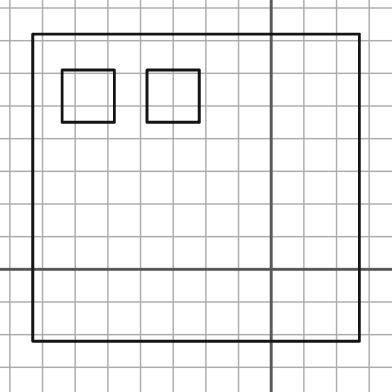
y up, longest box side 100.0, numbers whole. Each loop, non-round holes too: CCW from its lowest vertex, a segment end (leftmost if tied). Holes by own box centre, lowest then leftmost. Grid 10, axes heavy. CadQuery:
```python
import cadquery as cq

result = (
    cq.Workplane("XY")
    .moveTo(-73.0, -22.0)
    .lineTo(27.0, -22.0)
    .lineTo(27.0, 72.0)
    .lineTo(-73.0, 72.0)
    .close()
    .moveTo(-64.0, 45.0)
    .lineTo(-48.0, 45.0)
    .lineTo(-48.0, 61.0)
    .lineTo(-64.0, 61.0)
    .close()
    .moveTo(-38.0, 45.0)
    .lineTo(-22.0, 45.0)
    .lineTo(-22.0, 61.0)
    .lineTo(-38.0, 61.0)
    .close()
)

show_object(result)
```